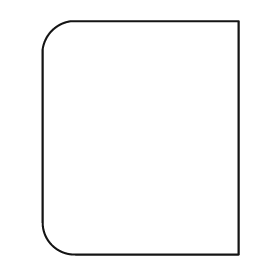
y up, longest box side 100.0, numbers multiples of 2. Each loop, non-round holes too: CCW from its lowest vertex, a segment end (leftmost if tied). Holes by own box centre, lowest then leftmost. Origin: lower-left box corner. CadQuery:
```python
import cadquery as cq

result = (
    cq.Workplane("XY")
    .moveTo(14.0, 0.0)
    .lineTo(84.0, 0.0)
    .lineTo(84.0, 100.0)
    .lineTo(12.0, 100.0)
    .threePointArc((4.0, 96.0), (0.0, 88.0))
    .lineTo(0.0, 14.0)
    .threePointArc((4.0, 4.0), (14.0, 0.0))
    .close()
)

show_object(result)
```